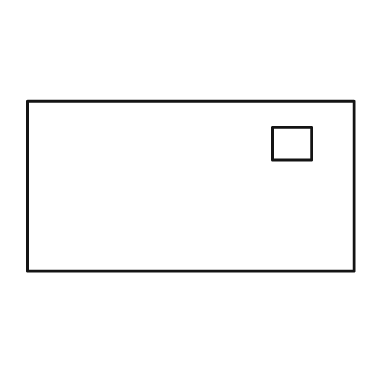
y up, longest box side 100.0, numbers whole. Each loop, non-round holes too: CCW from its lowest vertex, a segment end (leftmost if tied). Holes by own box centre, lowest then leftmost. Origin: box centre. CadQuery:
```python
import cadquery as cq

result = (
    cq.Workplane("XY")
    .moveTo(-50.0, -26.0)
    .lineTo(50.0, -26.0)
    .lineTo(50.0, 26.0)
    .lineTo(-50.0, 26.0)
    .close()
    .moveTo(25.0, 8.0)
    .lineTo(37.0, 8.0)
    .lineTo(37.0, 18.0)
    .lineTo(25.0, 18.0)
    .close()
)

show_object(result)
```